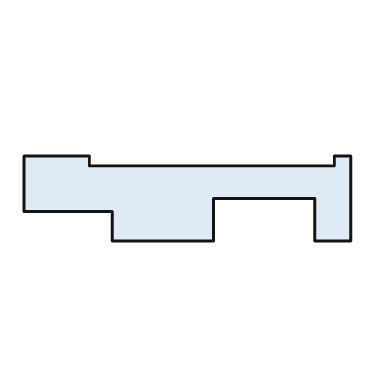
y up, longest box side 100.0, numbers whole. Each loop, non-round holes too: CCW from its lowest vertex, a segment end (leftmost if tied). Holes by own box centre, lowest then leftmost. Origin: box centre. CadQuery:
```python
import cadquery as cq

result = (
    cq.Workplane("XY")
    .moveTo(-23.0, -13.0)
    .lineTo(8.0, -13.0)
    .lineTo(8.0, 0.0)
    .lineTo(39.0, 0.0)
    .lineTo(39.0, -13.0)
    .lineTo(50.0, -13.0)
    .lineTo(50.0, 13.0)
    .lineTo(45.0, 13.0)
    .lineTo(45.0, 10.0)
    .lineTo(-30.0, 10.0)
    .lineTo(-30.0, 13.0)
    .lineTo(-50.0, 13.0)
    .lineTo(-50.0, -4.0)
    .lineTo(-23.0, -4.0)
    .close()
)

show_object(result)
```